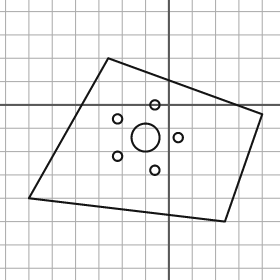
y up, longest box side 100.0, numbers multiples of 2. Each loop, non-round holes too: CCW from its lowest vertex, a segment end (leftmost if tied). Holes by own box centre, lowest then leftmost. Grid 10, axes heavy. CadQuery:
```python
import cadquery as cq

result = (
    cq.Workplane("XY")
    .moveTo(24.0, -50.0)
    .lineTo(40.0, -4.0)
    .lineTo(-26.0, 20.0)
    .lineTo(-60.0, -40.0)
    .close()
    .moveTo(-6.0, -28.0)
    .circle(2.0)
    .moveTo(-22.0, -22.0)
    .circle(2.0)
    .moveTo(-10.0, -14.0)
    .circle(6.0)
    .moveTo(4.0, -14.0)
    .circle(2.0)
    .moveTo(-22.0, -6.0)
    .circle(2.0)
    .moveTo(-6.0, 0.0)
    .circle(2.0)
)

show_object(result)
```